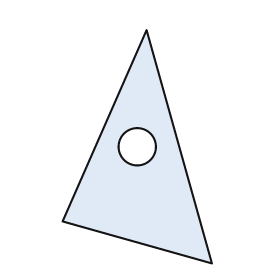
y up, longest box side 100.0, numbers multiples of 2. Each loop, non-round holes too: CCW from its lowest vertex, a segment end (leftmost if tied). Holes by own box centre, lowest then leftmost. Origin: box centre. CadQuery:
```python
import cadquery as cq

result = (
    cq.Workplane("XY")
    .moveTo(32.0, -50.0)
    .lineTo(4.0, 50.0)
    .lineTo(-32.0, -32.0)
    .close()
    .moveTo(0.0, 0.0)
    .circle(8.0)
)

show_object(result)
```